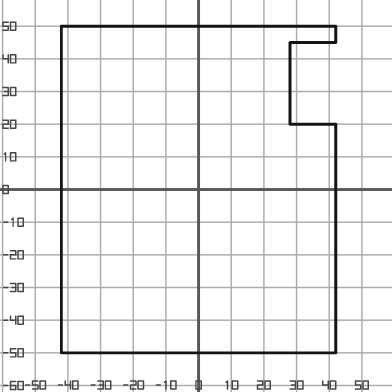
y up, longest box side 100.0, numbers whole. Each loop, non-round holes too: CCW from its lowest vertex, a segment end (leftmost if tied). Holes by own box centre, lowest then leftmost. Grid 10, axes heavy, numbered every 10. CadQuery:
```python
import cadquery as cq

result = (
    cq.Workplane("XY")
    .moveTo(-42.0, -50.0)
    .lineTo(42.0, -50.0)
    .lineTo(42.0, 20.0)
    .lineTo(28.0, 20.0)
    .lineTo(28.0, 45.0)
    .lineTo(42.0, 45.0)
    .lineTo(42.0, 50.0)
    .lineTo(-42.0, 50.0)
    .close()
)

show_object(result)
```